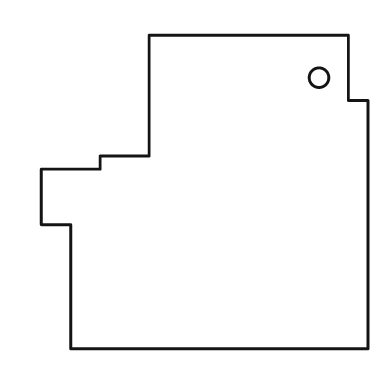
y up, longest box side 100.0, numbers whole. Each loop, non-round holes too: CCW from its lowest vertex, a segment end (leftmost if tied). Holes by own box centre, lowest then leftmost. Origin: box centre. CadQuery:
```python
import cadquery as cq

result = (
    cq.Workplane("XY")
    .moveTo(-41.0, -48.0)
    .lineTo(50.0, -48.0)
    .lineTo(50.0, 28.0)
    .lineTo(44.0, 28.0)
    .lineTo(44.0, 48.0)
    .lineTo(-17.0, 48.0)
    .lineTo(-17.0, 11.0)
    .lineTo(-32.0, 11.0)
    .lineTo(-32.0, 7.0)
    .lineTo(-50.0, 7.0)
    .lineTo(-50.0, -10.0)
    .lineTo(-41.0, -10.0)
    .close()
    .moveTo(35.0, 35.0)
    .circle(3.0)
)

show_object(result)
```